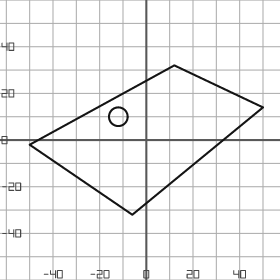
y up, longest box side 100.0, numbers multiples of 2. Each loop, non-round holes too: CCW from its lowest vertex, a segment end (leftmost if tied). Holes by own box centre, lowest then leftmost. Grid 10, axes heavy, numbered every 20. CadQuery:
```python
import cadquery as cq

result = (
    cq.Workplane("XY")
    .moveTo(-6.0, -32.0)
    .lineTo(50.0, 14.0)
    .lineTo(12.0, 32.0)
    .lineTo(-50.0, -2.0)
    .close()
    .moveTo(-12.0, 10.0)
    .circle(4.0)
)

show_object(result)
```